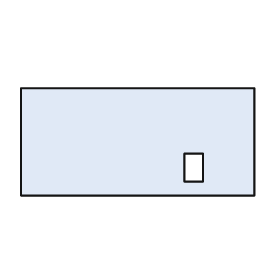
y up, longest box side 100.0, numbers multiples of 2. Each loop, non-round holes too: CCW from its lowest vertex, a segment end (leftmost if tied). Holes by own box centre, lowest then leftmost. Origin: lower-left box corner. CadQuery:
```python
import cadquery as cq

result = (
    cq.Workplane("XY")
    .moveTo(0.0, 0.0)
    .lineTo(100.0, 0.0)
    .lineTo(100.0, 46.0)
    .lineTo(0.0, 46.0)
    .close()
    .moveTo(70.0, 6.0)
    .lineTo(78.0, 6.0)
    .lineTo(78.0, 18.0)
    .lineTo(70.0, 18.0)
    .close()
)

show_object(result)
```